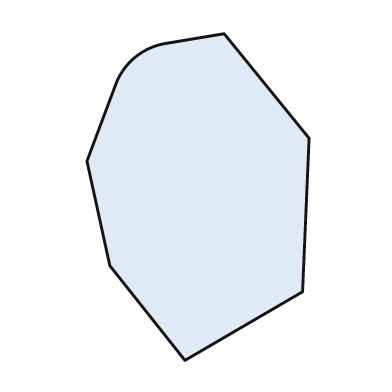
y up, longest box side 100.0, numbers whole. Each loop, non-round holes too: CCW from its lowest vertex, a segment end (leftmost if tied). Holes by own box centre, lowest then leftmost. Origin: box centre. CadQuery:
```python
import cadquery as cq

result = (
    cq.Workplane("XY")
    .moveTo(-4.0, -50.0)
    .lineTo(32.0, -29.0)
    .lineTo(34.0, 18.0)
    .lineTo(8.0, 50.0)
    .lineTo(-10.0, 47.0)
    .threePointArc((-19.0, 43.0), (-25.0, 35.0))
    .lineTo(-34.0, 11.0)
    .lineTo(-27.0, -21.0)
    .close()
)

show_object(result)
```